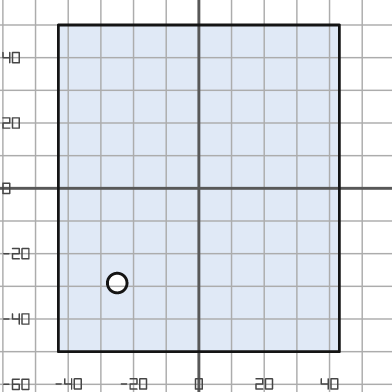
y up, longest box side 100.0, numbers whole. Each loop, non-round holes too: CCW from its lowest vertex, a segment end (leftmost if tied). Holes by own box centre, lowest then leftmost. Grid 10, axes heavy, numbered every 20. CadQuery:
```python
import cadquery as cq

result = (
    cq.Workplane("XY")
    .moveTo(-43.0, -50.0)
    .lineTo(43.0, -50.0)
    .lineTo(43.0, 50.0)
    .lineTo(-43.0, 50.0)
    .close()
    .moveTo(-25.0, -29.0)
    .circle(3.0)
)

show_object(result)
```